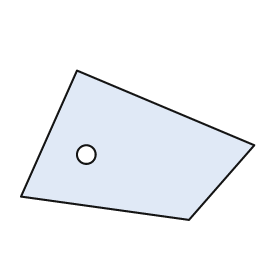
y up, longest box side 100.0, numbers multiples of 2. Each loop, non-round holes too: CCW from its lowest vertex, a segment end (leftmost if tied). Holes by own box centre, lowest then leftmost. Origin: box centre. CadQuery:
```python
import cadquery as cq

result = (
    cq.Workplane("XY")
    .moveTo(22.0, -32.0)
    .lineTo(50.0, 0.0)
    .lineTo(-26.0, 32.0)
    .lineTo(-50.0, -22.0)
    .close()
    .moveTo(-22.0, -4.0)
    .circle(4.0)
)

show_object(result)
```